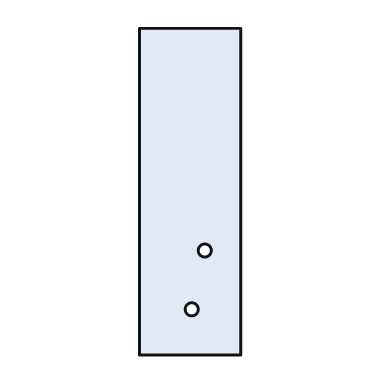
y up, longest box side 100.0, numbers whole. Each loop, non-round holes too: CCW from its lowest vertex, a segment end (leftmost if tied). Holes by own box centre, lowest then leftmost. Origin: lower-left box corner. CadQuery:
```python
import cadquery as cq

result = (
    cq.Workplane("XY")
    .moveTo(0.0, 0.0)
    .lineTo(31.0, 0.0)
    .lineTo(31.0, 100.0)
    .lineTo(0.0, 100.0)
    .close()
    .moveTo(16.0, 14.0)
    .circle(2.0)
    .moveTo(20.0, 32.0)
    .circle(2.0)
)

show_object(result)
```